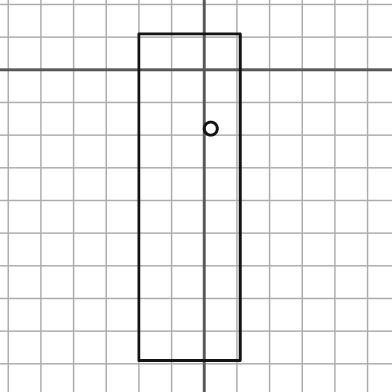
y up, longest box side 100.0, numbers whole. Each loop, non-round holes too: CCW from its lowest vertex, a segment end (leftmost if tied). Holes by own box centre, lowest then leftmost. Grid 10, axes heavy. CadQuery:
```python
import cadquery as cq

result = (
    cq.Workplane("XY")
    .moveTo(-20.0, -89.0)
    .lineTo(11.0, -89.0)
    .lineTo(11.0, 11.0)
    .lineTo(-20.0, 11.0)
    .close()
    .moveTo(2.0, -18.0)
    .circle(2.0)
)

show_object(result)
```